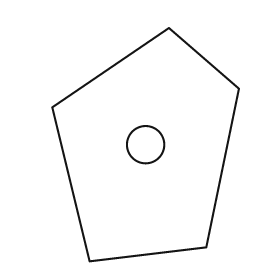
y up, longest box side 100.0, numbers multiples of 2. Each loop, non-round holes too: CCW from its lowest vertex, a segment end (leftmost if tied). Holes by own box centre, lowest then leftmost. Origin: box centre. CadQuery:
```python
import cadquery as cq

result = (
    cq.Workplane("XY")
    .moveTo(-24.0, -50.0)
    .lineTo(26.0, -44.0)
    .lineTo(40.0, 24.0)
    .lineTo(10.0, 50.0)
    .lineTo(-40.0, 16.0)
    .close()
    .moveTo(0.0, 0.0)
    .circle(8.0)
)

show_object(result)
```